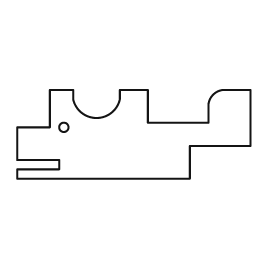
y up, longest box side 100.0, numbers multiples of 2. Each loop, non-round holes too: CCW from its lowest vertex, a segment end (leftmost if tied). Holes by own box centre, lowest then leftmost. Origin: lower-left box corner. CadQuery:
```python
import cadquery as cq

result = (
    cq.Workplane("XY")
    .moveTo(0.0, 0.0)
    .lineTo(74.0, 0.0)
    .lineTo(74.0, 14.0)
    .lineTo(100.0, 14.0)
    .lineTo(100.0, 38.0)
    .lineTo(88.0, 38.0)
    .threePointArc((84.0, 36.0), (82.0, 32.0))
    .lineTo(82.0, 24.0)
    .lineTo(56.0, 24.0)
    .lineTo(56.0, 38.0)
    .lineTo(44.0, 38.0)
    .lineTo(44.0, 34.0)
    .threePointArc((34.0, 26.0), (24.0, 34.0))
    .lineTo(24.0, 38.0)
    .lineTo(14.0, 38.0)
    .lineTo(14.0, 22.0)
    .lineTo(0.0, 22.0)
    .lineTo(0.0, 8.0)
    .lineTo(18.0, 8.0)
    .lineTo(18.0, 4.0)
    .lineTo(0.0, 4.0)
    .close()
    .moveTo(20.0, 22.0)
    .circle(2.0)
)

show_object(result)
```